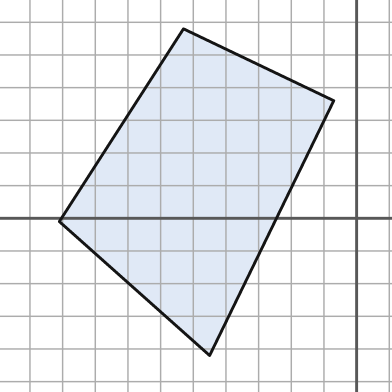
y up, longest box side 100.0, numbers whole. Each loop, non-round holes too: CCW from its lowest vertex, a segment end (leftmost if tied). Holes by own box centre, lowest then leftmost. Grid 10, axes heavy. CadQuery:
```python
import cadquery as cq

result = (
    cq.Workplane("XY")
    .moveTo(-45.0, -42.0)
    .lineTo(-7.0, 36.0)
    .lineTo(-53.0, 58.0)
    .lineTo(-91.0, -1.0)
    .close()
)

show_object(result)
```